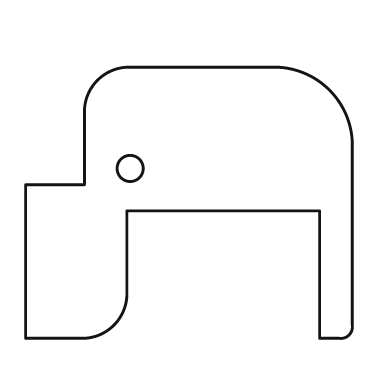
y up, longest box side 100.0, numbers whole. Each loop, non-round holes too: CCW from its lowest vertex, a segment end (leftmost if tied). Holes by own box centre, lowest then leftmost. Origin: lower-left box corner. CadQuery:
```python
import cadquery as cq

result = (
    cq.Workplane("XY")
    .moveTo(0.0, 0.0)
    .lineTo(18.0, 0.0)
    .threePointArc((27.0, 4.0), (31.0, 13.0))
    .lineTo(31.0, 39.0)
    .lineTo(90.0, 39.0)
    .lineTo(90.0, 0.0)
    .lineTo(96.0, 0.0)
    .threePointArc((99.0, 1.0), (100.0, 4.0))
    .lineTo(100.0, 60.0)
    .threePointArc((93.0, 76.0), (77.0, 83.0))
    .lineTo(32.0, 83.0)
    .threePointArc((22.0, 79.0), (18.0, 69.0))
    .lineTo(18.0, 47.0)
    .lineTo(0.0, 47.0)
    .close()
    .moveTo(32.0, 52.0)
    .circle(4.0)
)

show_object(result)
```